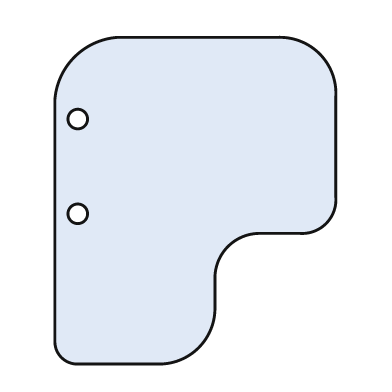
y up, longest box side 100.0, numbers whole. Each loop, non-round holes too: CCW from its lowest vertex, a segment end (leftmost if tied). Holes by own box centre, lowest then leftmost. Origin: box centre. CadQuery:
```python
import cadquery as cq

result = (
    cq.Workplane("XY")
    .moveTo(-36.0, -50.0)
    .lineTo(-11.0, -50.0)
    .threePointArc((1.0, -45.0), (6.0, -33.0))
    .lineTo(6.0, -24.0)
    .threePointArc((10.0, -14.0), (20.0, -10.0))
    .lineTo(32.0, -10.0)
    .threePointArc((40.0, -7.0), (43.0, 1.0))
    .lineTo(43.0, 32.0)
    .threePointArc((38.0, 45.0), (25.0, 50.0))
    .lineTo(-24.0, 50.0)
    .threePointArc((-37.0, 44.0), (-43.0, 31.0))
    .lineTo(-43.0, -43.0)
    .threePointArc((-41.0, -48.0), (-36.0, -50.0))
    .close()
    .moveTo(-36.0, -4.0)
    .circle(3.0)
    .moveTo(-36.0, 25.0)
    .circle(3.0)
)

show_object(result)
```